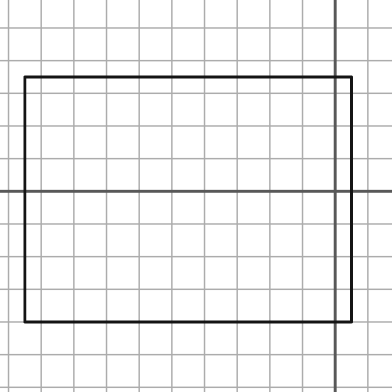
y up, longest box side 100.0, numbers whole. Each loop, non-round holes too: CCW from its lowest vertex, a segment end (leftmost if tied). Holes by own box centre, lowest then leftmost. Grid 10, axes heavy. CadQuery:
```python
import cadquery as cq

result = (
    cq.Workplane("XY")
    .moveTo(-95.0, -40.0)
    .lineTo(5.0, -40.0)
    .lineTo(5.0, 35.0)
    .lineTo(-95.0, 35.0)
    .close()
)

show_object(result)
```